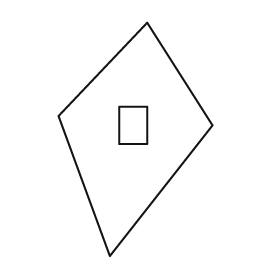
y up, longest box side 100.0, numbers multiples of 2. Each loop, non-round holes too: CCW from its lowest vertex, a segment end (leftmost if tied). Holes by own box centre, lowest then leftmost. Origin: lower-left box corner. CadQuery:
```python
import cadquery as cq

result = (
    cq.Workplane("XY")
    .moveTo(22.0, 0.0)
    .lineTo(66.0, 56.0)
    .lineTo(38.0, 100.0)
    .lineTo(0.0, 60.0)
    .close()
    .moveTo(26.0, 48.0)
    .lineTo(38.0, 48.0)
    .lineTo(38.0, 64.0)
    .lineTo(26.0, 64.0)
    .close()
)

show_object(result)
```